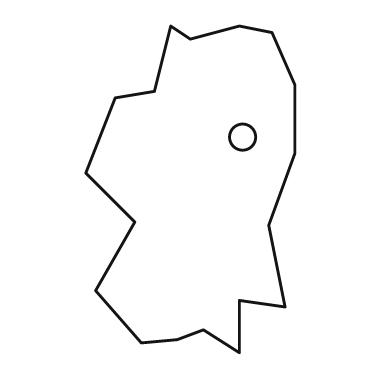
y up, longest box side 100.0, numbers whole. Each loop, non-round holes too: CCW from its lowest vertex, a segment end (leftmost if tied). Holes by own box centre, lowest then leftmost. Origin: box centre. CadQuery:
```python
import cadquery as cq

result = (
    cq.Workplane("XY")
    .moveTo(15.0, -50.0)
    .lineTo(15.0, -34.0)
    .lineTo(29.0, -36.0)
    .lineTo(24.0, -11.0)
    .lineTo(32.0, 11.0)
    .lineTo(32.0, 32.0)
    .lineTo(25.0, 48.0)
    .lineTo(15.0, 50.0)
    .lineTo(0.0, 46.0)
    .lineTo(-6.0, 50.0)
    .lineTo(-11.0, 30.0)
    .lineTo(-23.0, 28.0)
    .lineTo(-32.0, 5.0)
    .lineTo(-17.0, -10.0)
    .lineTo(-29.0, -31.0)
    .lineTo(-15.0, -47.0)
    .lineTo(-4.0, -46.0)
    .lineTo(4.0, -43.0)
    .close()
    .moveTo(16.0, 16.0)
    .circle(4.0)
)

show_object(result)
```